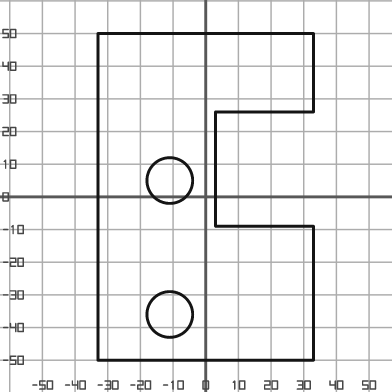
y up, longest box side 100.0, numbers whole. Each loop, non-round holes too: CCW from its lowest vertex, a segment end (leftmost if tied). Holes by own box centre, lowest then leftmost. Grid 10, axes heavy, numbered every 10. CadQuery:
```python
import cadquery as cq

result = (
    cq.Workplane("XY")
    .moveTo(-33.0, -50.0)
    .lineTo(33.0, -50.0)
    .lineTo(33.0, -9.0)
    .lineTo(3.0, -9.0)
    .lineTo(3.0, 26.0)
    .lineTo(33.0, 26.0)
    .lineTo(33.0, 50.0)
    .lineTo(-33.0, 50.0)
    .close()
    .moveTo(-11.0, -36.0)
    .circle(7.0)
    .moveTo(-11.0, 5.0)
    .circle(7.0)
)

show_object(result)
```